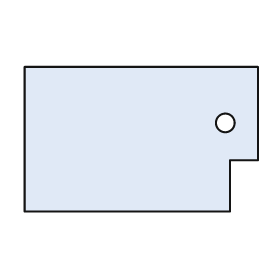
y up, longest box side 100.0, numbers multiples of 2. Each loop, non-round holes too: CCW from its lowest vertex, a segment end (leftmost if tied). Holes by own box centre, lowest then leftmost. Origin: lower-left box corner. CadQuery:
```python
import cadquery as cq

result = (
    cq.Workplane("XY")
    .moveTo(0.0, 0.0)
    .lineTo(88.0, 0.0)
    .lineTo(88.0, 22.0)
    .lineTo(100.0, 22.0)
    .lineTo(100.0, 62.0)
    .lineTo(0.0, 62.0)
    .close()
    .moveTo(86.0, 38.0)
    .circle(4.0)
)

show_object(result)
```